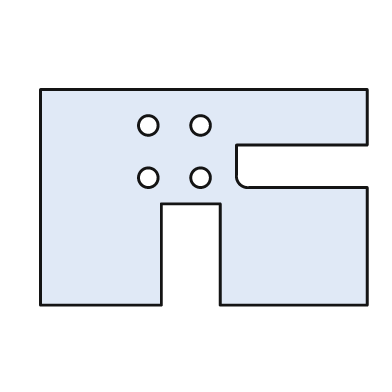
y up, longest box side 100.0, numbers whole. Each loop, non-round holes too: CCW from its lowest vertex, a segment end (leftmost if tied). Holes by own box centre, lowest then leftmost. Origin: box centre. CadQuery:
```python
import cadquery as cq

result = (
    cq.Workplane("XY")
    .moveTo(-50.0, -33.0)
    .lineTo(-13.0, -33.0)
    .lineTo(-13.0, -2.0)
    .lineTo(5.0, -2.0)
    .lineTo(5.0, -33.0)
    .lineTo(50.0, -33.0)
    .lineTo(50.0, 3.0)
    .lineTo(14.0, 3.0)
    .threePointArc((11.0, 4.0), (10.0, 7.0))
    .lineTo(10.0, 16.0)
    .lineTo(50.0, 16.0)
    .lineTo(50.0, 33.0)
    .lineTo(-50.0, 33.0)
    .close()
    .moveTo(-17.0, 6.0)
    .circle(3.0)
    .moveTo(-1.0, 6.0)
    .circle(3.0)
    .moveTo(-17.0, 22.0)
    .circle(3.0)
    .moveTo(-1.0, 22.0)
    .circle(3.0)
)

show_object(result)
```